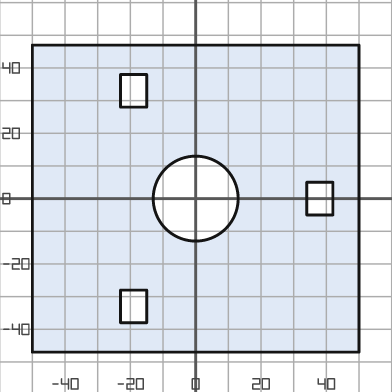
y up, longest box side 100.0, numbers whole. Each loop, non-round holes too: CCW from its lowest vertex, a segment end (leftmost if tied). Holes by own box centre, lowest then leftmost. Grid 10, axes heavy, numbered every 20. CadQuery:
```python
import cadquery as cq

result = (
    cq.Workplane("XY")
    .moveTo(-50.0, -47.0)
    .lineTo(50.0, -47.0)
    .lineTo(50.0, 47.0)
    .lineTo(-50.0, 47.0)
    .close()
    .moveTo(-23.0, -38.0)
    .lineTo(-15.0, -38.0)
    .lineTo(-15.0, -28.0)
    .lineTo(-23.0, -28.0)
    .close()
    .moveTo(0.0, 0.0)
    .circle(13.0)
    .moveTo(34.0, -5.0)
    .lineTo(42.0, -5.0)
    .lineTo(42.0, 5.0)
    .lineTo(34.0, 5.0)
    .close()
    .moveTo(-23.0, 28.0)
    .lineTo(-15.0, 28.0)
    .lineTo(-15.0, 38.0)
    .lineTo(-23.0, 38.0)
    .close()
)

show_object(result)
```